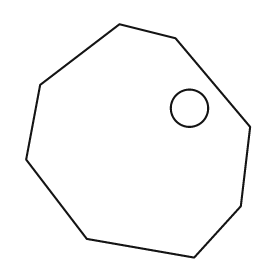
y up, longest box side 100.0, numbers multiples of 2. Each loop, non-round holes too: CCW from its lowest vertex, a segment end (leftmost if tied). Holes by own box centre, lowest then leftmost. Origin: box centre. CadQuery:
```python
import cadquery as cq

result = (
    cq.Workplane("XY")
    .moveTo(24.0, -50.0)
    .lineTo(44.0, -28.0)
    .lineTo(48.0, 6.0)
    .lineTo(16.0, 44.0)
    .lineTo(-8.0, 50.0)
    .lineTo(-42.0, 24.0)
    .lineTo(-48.0, -8.0)
    .lineTo(-22.0, -42.0)
    .close()
    .moveTo(22.0, 14.0)
    .circle(8.0)
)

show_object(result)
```